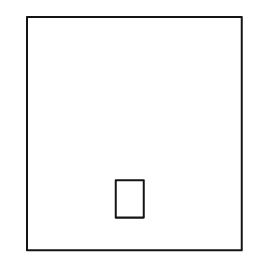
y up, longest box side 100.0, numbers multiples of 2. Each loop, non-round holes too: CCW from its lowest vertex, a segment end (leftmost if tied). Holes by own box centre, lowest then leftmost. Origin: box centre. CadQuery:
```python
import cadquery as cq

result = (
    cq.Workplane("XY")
    .moveTo(-46.0, -50.0)
    .lineTo(46.0, -50.0)
    .lineTo(46.0, 50.0)
    .lineTo(-46.0, 50.0)
    .close()
    .moveTo(-8.0, -36.0)
    .lineTo(4.0, -36.0)
    .lineTo(4.0, -20.0)
    .lineTo(-8.0, -20.0)
    .close()
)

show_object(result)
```